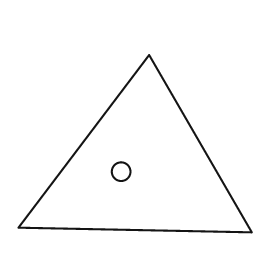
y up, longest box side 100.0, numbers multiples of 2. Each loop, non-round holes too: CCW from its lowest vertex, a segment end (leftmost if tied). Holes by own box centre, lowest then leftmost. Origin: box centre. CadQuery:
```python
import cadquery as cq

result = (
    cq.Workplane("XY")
    .moveTo(50.0, -38.0)
    .lineTo(6.0, 38.0)
    .lineTo(-50.0, -36.0)
    .close()
    .moveTo(-6.0, -12.0)
    .circle(4.0)
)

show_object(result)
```